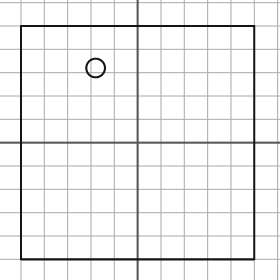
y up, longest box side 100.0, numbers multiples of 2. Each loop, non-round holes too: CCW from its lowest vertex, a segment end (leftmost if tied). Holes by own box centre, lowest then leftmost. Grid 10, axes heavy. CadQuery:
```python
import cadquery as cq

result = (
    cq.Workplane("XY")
    .moveTo(-50.0, -50.0)
    .lineTo(50.0, -50.0)
    .lineTo(50.0, 50.0)
    .lineTo(-50.0, 50.0)
    .close()
    .moveTo(-18.0, 32.0)
    .circle(4.0)
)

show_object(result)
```